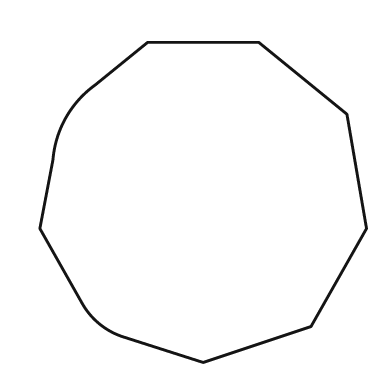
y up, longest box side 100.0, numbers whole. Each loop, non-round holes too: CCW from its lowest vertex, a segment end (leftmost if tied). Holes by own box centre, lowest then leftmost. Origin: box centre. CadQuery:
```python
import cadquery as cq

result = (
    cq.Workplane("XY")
    .moveTo(0.0, -49.0)
    .lineTo(33.0, -38.0)
    .lineTo(50.0, -8.0)
    .lineTo(44.0, 27.0)
    .lineTo(17.0, 49.0)
    .lineTo(-17.0, 49.0)
    .lineTo(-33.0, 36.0)
    .threePointArc((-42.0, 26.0), (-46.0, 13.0))
    .lineTo(-50.0, -8.0)
    .lineTo(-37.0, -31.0)
    .threePointArc((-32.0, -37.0), (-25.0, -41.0))
    .close()
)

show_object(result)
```